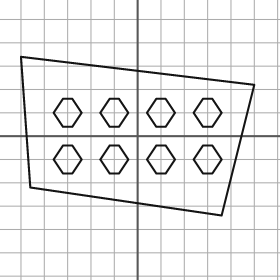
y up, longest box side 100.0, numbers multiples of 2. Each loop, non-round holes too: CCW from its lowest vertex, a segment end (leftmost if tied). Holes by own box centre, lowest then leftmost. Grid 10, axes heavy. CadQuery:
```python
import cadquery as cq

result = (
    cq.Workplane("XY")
    .moveTo(36.0, -34.0)
    .lineTo(50.0, 22.0)
    .lineTo(-50.0, 34.0)
    .lineTo(-46.0, -22.0)
    .close()
    .moveTo(-32.0, -16.0)
    .lineTo(-28.0, -16.0)
    .lineTo(-24.0, -10.0)
    .lineTo(-28.0, -4.0)
    .lineTo(-32.0, -4.0)
    .lineTo(-36.0, -10.0)
    .close()
    .moveTo(-12.0, -16.0)
    .lineTo(-8.0, -16.0)
    .lineTo(-4.0, -10.0)
    .lineTo(-8.0, -4.0)
    .lineTo(-12.0, -4.0)
    .lineTo(-16.0, -10.0)
    .close()
    .moveTo(8.0, -16.0)
    .lineTo(12.0, -16.0)
    .lineTo(16.0, -10.0)
    .lineTo(12.0, -4.0)
    .lineTo(8.0, -4.0)
    .lineTo(4.0, -10.0)
    .close()
    .moveTo(28.0, -16.0)
    .lineTo(32.0, -16.0)
    .lineTo(36.0, -10.0)
    .lineTo(32.0, -4.0)
    .lineTo(28.0, -4.0)
    .lineTo(24.0, -10.0)
    .close()
    .moveTo(-32.0, 4.0)
    .lineTo(-28.0, 4.0)
    .lineTo(-24.0, 10.0)
    .lineTo(-28.0, 16.0)
    .lineTo(-32.0, 16.0)
    .lineTo(-36.0, 10.0)
    .close()
    .moveTo(-12.0, 4.0)
    .lineTo(-8.0, 4.0)
    .lineTo(-4.0, 10.0)
    .lineTo(-8.0, 16.0)
    .lineTo(-12.0, 16.0)
    .lineTo(-16.0, 10.0)
    .close()
    .moveTo(8.0, 4.0)
    .lineTo(12.0, 4.0)
    .lineTo(16.0, 10.0)
    .lineTo(12.0, 16.0)
    .lineTo(8.0, 16.0)
    .lineTo(4.0, 10.0)
    .close()
    .moveTo(28.0, 4.0)
    .lineTo(32.0, 4.0)
    .lineTo(36.0, 10.0)
    .lineTo(32.0, 16.0)
    .lineTo(28.0, 16.0)
    .lineTo(24.0, 10.0)
    .close()
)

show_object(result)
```